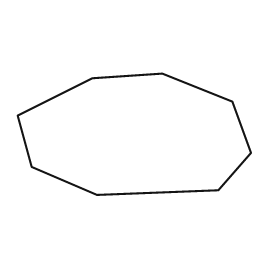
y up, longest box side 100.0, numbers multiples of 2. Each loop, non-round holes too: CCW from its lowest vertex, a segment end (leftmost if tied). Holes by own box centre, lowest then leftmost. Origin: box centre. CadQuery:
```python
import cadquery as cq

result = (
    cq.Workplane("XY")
    .moveTo(-16.0, -26.0)
    .lineTo(36.0, -24.0)
    .lineTo(50.0, -8.0)
    .lineTo(42.0, 14.0)
    .lineTo(12.0, 26.0)
    .lineTo(-18.0, 24.0)
    .lineTo(-50.0, 8.0)
    .lineTo(-44.0, -14.0)
    .close()
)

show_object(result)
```